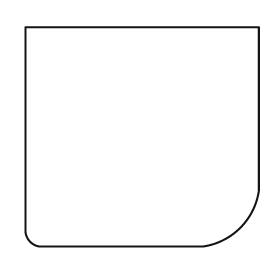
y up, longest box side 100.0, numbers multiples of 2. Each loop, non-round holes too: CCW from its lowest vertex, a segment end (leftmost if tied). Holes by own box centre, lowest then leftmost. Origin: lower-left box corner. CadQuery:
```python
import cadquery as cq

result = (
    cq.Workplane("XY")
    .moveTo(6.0, 0.0)
    .lineTo(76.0, 0.0)
    .threePointArc((92.0, 8.0), (100.0, 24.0))
    .lineTo(100.0, 94.0)
    .lineTo(0.0, 94.0)
    .lineTo(0.0, 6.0)
    .threePointArc((2.0, 2.0), (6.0, 0.0))
    .close()
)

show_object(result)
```